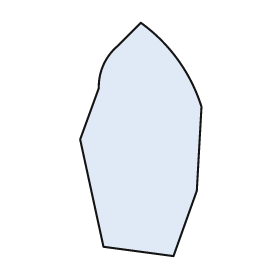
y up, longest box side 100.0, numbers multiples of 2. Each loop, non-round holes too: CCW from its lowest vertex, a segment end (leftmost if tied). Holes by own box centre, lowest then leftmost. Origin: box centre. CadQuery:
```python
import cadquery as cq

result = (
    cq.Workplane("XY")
    .moveTo(14.0, -50.0)
    .lineTo(24.0, -22.0)
    .lineTo(26.0, 14.0)
    .threePointArc((16.0, 34.0), (0.0, 50.0))
    .lineTo(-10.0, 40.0)
    .threePointArc((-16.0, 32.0), (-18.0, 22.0))
    .lineTo(-26.0, 0.0)
    .lineTo(-16.0, -46.0)
    .close()
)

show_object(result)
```